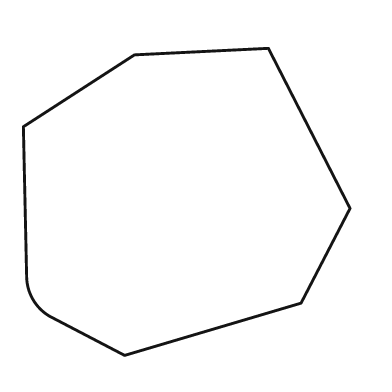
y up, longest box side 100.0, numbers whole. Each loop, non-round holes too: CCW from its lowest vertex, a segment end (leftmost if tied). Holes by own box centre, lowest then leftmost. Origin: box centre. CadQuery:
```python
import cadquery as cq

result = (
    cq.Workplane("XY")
    .moveTo(-19.0, -47.0)
    .lineTo(35.0, -31.0)
    .lineTo(50.0, -2.0)
    .lineTo(25.0, 47.0)
    .lineTo(-16.0, 45.0)
    .lineTo(-50.0, 23.0)
    .lineTo(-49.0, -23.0)
    .threePointArc((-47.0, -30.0), (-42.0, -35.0))
    .close()
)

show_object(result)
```